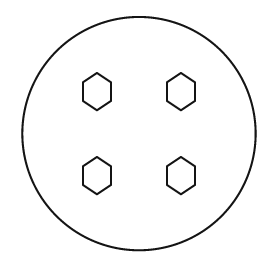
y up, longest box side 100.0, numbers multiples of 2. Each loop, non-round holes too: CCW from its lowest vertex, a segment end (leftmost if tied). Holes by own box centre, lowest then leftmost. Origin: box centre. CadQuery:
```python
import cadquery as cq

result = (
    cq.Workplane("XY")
    .moveTo(0.0, 0.0)
    .circle(50.0)
    .moveTo(-18.0, -26.0)
    .lineTo(-12.0, -22.0)
    .lineTo(-12.0, -14.0)
    .lineTo(-18.0, -10.0)
    .lineTo(-24.0, -14.0)
    .lineTo(-24.0, -22.0)
    .close()
    .moveTo(18.0, -26.0)
    .lineTo(24.0, -22.0)
    .lineTo(24.0, -14.0)
    .lineTo(18.0, -10.0)
    .lineTo(12.0, -14.0)
    .lineTo(12.0, -22.0)
    .close()
    .moveTo(-18.0, 10.0)
    .lineTo(-12.0, 14.0)
    .lineTo(-12.0, 22.0)
    .lineTo(-18.0, 26.0)
    .lineTo(-24.0, 22.0)
    .lineTo(-24.0, 14.0)
    .close()
    .moveTo(18.0, 10.0)
    .lineTo(24.0, 14.0)
    .lineTo(24.0, 22.0)
    .lineTo(18.0, 26.0)
    .lineTo(12.0, 22.0)
    .lineTo(12.0, 14.0)
    .close()
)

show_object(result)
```